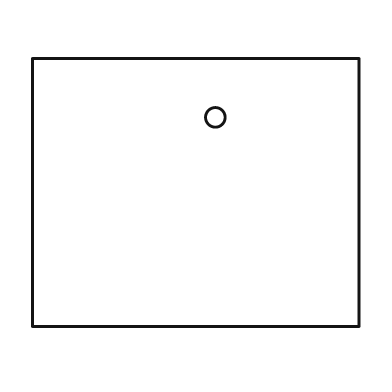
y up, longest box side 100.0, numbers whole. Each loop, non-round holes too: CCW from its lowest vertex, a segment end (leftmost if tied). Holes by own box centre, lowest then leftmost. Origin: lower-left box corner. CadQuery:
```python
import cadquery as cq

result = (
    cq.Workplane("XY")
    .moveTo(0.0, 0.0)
    .lineTo(100.0, 0.0)
    .lineTo(100.0, 82.0)
    .lineTo(0.0, 82.0)
    .close()
    .moveTo(56.0, 64.0)
    .circle(3.0)
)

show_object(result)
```